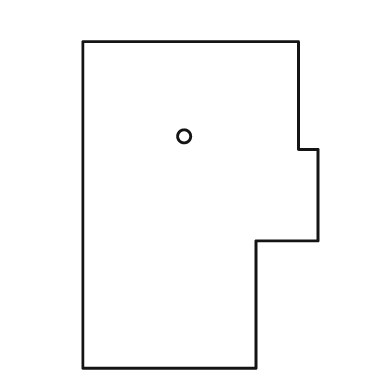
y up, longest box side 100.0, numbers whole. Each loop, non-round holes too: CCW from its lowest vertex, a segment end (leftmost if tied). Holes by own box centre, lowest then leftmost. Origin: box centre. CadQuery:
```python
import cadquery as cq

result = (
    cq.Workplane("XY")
    .moveTo(-36.0, -50.0)
    .lineTo(17.0, -50.0)
    .lineTo(17.0, -11.0)
    .lineTo(36.0, -11.0)
    .lineTo(36.0, 17.0)
    .lineTo(30.0, 17.0)
    .lineTo(30.0, 50.0)
    .lineTo(-36.0, 50.0)
    .close()
    .moveTo(-5.0, 21.0)
    .circle(2.0)
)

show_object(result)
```